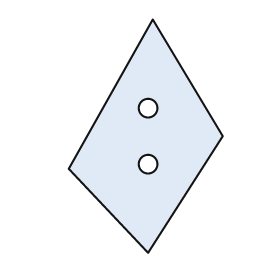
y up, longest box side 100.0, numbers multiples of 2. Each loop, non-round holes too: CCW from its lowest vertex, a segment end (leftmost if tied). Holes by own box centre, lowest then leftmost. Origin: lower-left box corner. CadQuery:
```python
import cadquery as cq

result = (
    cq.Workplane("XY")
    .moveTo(34.0, 0.0)
    .lineTo(66.0, 50.0)
    .lineTo(36.0, 100.0)
    .lineTo(0.0, 36.0)
    .close()
    .moveTo(34.0, 38.0)
    .circle(4.0)
    .moveTo(34.0, 62.0)
    .circle(4.0)
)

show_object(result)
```